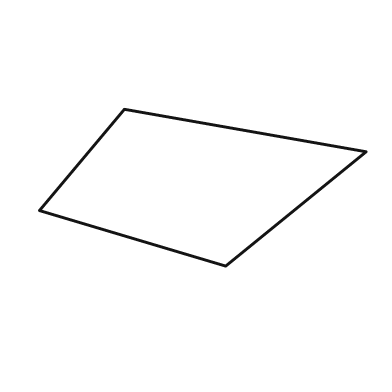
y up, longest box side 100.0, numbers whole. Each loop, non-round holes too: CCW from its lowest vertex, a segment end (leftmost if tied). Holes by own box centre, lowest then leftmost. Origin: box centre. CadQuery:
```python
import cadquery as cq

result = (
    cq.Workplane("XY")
    .moveTo(7.0, -24.0)
    .lineTo(50.0, 11.0)
    .lineTo(-24.0, 24.0)
    .lineTo(-50.0, -7.0)
    .close()
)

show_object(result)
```